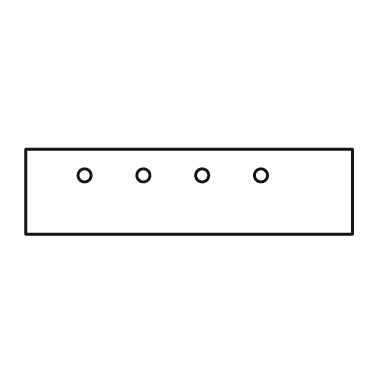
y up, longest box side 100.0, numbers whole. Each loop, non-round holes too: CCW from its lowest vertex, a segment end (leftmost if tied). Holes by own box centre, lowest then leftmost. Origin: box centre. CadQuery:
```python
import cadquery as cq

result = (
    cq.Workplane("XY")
    .moveTo(-50.0, -13.0)
    .lineTo(50.0, -13.0)
    .lineTo(50.0, 13.0)
    .lineTo(-50.0, 13.0)
    .close()
    .moveTo(-32.0, 5.0)
    .circle(2.0)
    .moveTo(-14.0, 5.0)
    .circle(2.0)
    .moveTo(4.0, 5.0)
    .circle(2.0)
    .moveTo(22.0, 5.0)
    .circle(2.0)
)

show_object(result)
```